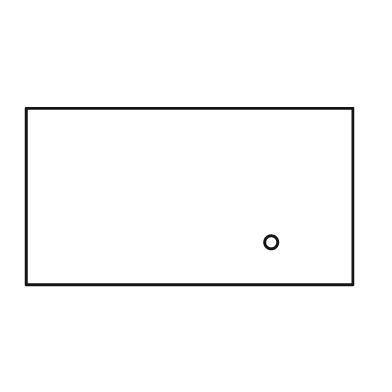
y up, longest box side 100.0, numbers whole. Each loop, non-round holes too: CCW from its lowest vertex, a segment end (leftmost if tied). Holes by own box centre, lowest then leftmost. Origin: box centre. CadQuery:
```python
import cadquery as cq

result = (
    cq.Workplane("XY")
    .moveTo(-50.0, -27.0)
    .lineTo(50.0, -27.0)
    .lineTo(50.0, 27.0)
    .lineTo(-50.0, 27.0)
    .close()
    .moveTo(25.0, -14.0)
    .circle(2.0)
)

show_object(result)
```